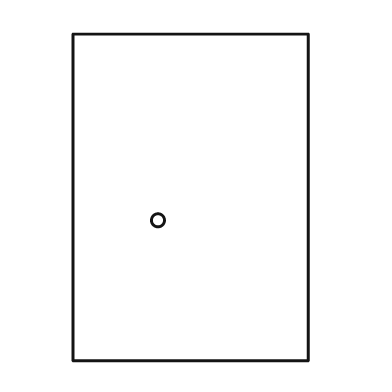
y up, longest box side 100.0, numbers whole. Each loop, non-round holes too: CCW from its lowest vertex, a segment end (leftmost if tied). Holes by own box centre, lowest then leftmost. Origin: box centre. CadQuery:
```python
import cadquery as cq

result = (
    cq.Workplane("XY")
    .moveTo(-36.0, -50.0)
    .lineTo(36.0, -50.0)
    .lineTo(36.0, 50.0)
    .lineTo(-36.0, 50.0)
    .close()
    .moveTo(-10.0, -7.0)
    .circle(2.0)
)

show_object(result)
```